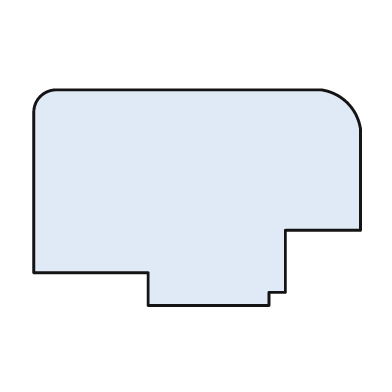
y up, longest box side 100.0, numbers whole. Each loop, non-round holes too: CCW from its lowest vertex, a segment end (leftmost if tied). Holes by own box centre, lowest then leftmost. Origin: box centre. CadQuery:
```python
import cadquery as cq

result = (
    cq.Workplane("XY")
    .moveTo(-15.0, -33.0)
    .lineTo(22.0, -33.0)
    .lineTo(22.0, -29.0)
    .lineTo(27.0, -29.0)
    .lineTo(27.0, -10.0)
    .lineTo(50.0, -10.0)
    .lineTo(50.0, 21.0)
    .threePointArc((46.0, 29.0), (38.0, 33.0))
    .lineTo(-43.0, 33.0)
    .threePointArc((-48.0, 31.0), (-50.0, 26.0))
    .lineTo(-50.0, -23.0)
    .lineTo(-15.0, -23.0)
    .close()
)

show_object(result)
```